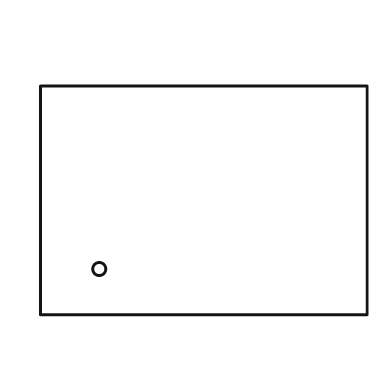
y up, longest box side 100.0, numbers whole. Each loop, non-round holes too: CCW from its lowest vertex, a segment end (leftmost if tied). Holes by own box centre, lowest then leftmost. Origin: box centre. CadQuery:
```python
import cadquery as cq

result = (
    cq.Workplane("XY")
    .moveTo(-50.0, -35.0)
    .lineTo(50.0, -35.0)
    .lineTo(50.0, 35.0)
    .lineTo(-50.0, 35.0)
    .close()
    .moveTo(-32.0, -21.0)
    .circle(2.0)
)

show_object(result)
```